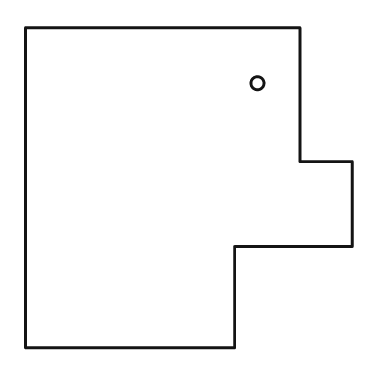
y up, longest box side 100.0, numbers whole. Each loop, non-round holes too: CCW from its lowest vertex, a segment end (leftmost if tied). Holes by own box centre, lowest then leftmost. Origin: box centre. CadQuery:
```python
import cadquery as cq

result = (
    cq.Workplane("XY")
    .moveTo(-50.0, -49.0)
    .lineTo(14.0, -49.0)
    .lineTo(14.0, -18.0)
    .lineTo(50.0, -18.0)
    .lineTo(50.0, 8.0)
    .lineTo(34.0, 8.0)
    .lineTo(34.0, 49.0)
    .lineTo(-50.0, 49.0)
    .close()
    .moveTo(21.0, 32.0)
    .circle(2.0)
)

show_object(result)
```